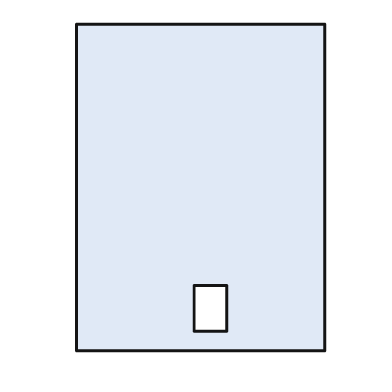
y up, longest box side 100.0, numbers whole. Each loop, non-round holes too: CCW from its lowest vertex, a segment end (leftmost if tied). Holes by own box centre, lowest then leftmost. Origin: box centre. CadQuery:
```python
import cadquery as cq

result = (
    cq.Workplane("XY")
    .moveTo(-38.0, -50.0)
    .lineTo(38.0, -50.0)
    .lineTo(38.0, 50.0)
    .lineTo(-38.0, 50.0)
    .close()
    .moveTo(-2.0, -44.0)
    .lineTo(8.0, -44.0)
    .lineTo(8.0, -30.0)
    .lineTo(-2.0, -30.0)
    .close()
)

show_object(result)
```